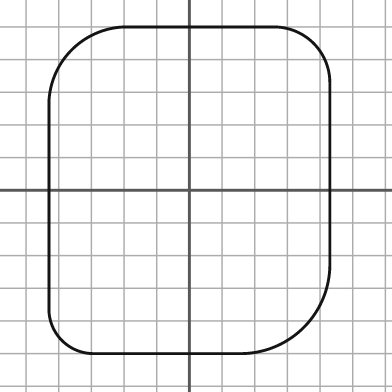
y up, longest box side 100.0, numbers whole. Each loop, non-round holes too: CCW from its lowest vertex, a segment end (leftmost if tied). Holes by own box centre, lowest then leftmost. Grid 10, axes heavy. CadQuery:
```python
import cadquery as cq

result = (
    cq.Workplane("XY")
    .moveTo(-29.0, -50.0)
    .lineTo(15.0, -50.0)
    .threePointArc((35.0, -42.0), (43.0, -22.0))
    .lineTo(43.0, 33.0)
    .threePointArc((38.0, 45.0), (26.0, 50.0))
    .lineTo(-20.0, 50.0)
    .threePointArc((-36.0, 43.0), (-43.0, 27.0))
    .lineTo(-43.0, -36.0)
    .threePointArc((-39.0, -46.0), (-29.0, -50.0))
    .close()
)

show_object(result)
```